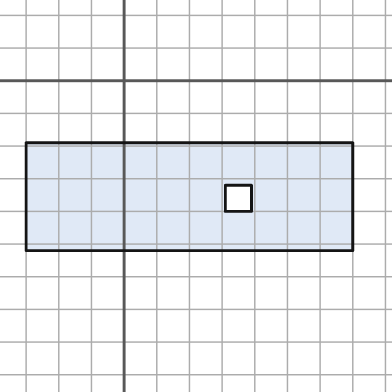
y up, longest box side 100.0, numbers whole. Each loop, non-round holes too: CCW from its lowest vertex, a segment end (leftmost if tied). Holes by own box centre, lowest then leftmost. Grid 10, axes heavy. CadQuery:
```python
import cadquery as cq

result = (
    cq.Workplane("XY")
    .moveTo(-30.0, -52.0)
    .lineTo(70.0, -52.0)
    .lineTo(70.0, -19.0)
    .lineTo(-30.0, -19.0)
    .close()
    .moveTo(31.0, -40.0)
    .lineTo(39.0, -40.0)
    .lineTo(39.0, -32.0)
    .lineTo(31.0, -32.0)
    .close()
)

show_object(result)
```